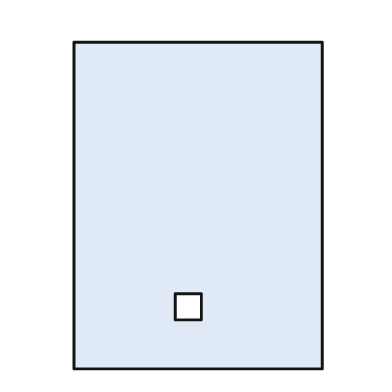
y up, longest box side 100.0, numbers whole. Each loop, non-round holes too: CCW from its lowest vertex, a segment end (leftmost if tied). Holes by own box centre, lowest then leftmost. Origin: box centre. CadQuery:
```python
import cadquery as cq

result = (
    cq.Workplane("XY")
    .moveTo(-38.0, -50.0)
    .lineTo(38.0, -50.0)
    .lineTo(38.0, 50.0)
    .lineTo(-38.0, 50.0)
    .close()
    .moveTo(-7.0, -35.0)
    .lineTo(1.0, -35.0)
    .lineTo(1.0, -27.0)
    .lineTo(-7.0, -27.0)
    .close()
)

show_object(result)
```